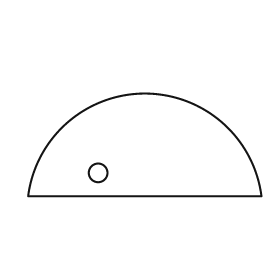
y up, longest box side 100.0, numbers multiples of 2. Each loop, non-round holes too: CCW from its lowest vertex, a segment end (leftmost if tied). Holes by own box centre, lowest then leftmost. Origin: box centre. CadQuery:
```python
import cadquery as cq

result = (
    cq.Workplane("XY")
    .moveTo(-50.0, -22.0)
    .lineTo(50.0, -22.0)
    .threePointArc((0.0, 22.0), (-50.0, -22.0))
    .close()
    .moveTo(-20.0, -12.0)
    .circle(4.0)
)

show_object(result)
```